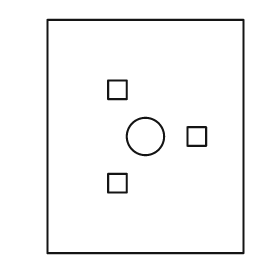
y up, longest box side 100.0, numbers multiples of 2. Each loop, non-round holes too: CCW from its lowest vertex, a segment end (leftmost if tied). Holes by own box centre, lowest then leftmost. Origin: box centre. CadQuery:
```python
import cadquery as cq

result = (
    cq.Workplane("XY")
    .moveTo(-42.0, -50.0)
    .lineTo(42.0, -50.0)
    .lineTo(42.0, 50.0)
    .lineTo(-42.0, 50.0)
    .close()
    .moveTo(-16.0, -24.0)
    .lineTo(-8.0, -24.0)
    .lineTo(-8.0, -16.0)
    .lineTo(-16.0, -16.0)
    .close()
    .moveTo(0.0, 0.0)
    .circle(8.0)
    .moveTo(18.0, -4.0)
    .lineTo(26.0, -4.0)
    .lineTo(26.0, 4.0)
    .lineTo(18.0, 4.0)
    .close()
    .moveTo(-16.0, 16.0)
    .lineTo(-8.0, 16.0)
    .lineTo(-8.0, 24.0)
    .lineTo(-16.0, 24.0)
    .close()
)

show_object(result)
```